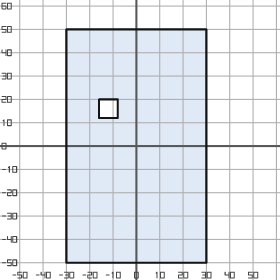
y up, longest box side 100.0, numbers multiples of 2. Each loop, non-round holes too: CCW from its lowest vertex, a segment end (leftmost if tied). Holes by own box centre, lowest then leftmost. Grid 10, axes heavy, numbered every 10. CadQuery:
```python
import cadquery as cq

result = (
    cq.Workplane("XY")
    .moveTo(-30.0, -50.0)
    .lineTo(30.0, -50.0)
    .lineTo(30.0, 50.0)
    .lineTo(-30.0, 50.0)
    .close()
    .moveTo(-16.0, 12.0)
    .lineTo(-8.0, 12.0)
    .lineTo(-8.0, 20.0)
    .lineTo(-16.0, 20.0)
    .close()
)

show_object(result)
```